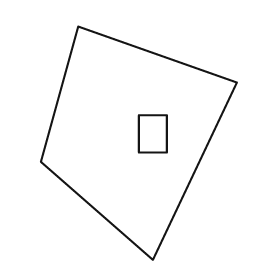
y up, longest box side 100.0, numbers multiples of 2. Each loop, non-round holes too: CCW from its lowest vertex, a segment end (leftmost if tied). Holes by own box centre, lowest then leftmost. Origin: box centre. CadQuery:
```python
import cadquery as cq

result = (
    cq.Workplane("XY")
    .moveTo(6.0, -50.0)
    .lineTo(42.0, 26.0)
    .lineTo(-26.0, 50.0)
    .lineTo(-42.0, -8.0)
    .close()
    .moveTo(0.0, -4.0)
    .lineTo(12.0, -4.0)
    .lineTo(12.0, 12.0)
    .lineTo(0.0, 12.0)
    .close()
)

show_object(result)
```